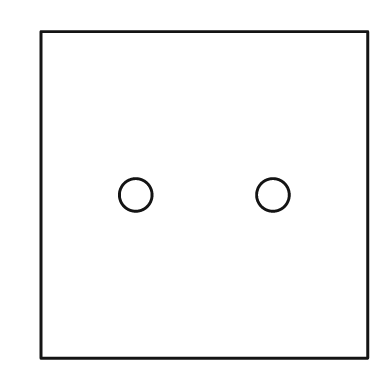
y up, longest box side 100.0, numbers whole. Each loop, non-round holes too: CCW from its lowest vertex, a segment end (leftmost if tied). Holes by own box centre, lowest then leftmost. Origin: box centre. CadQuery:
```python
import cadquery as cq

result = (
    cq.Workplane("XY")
    .moveTo(-50.0, -50.0)
    .lineTo(50.0, -50.0)
    .lineTo(50.0, 50.0)
    .lineTo(-50.0, 50.0)
    .close()
    .moveTo(-21.0, 0.0)
    .circle(5.0)
    .moveTo(21.0, 0.0)
    .circle(5.0)
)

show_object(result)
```